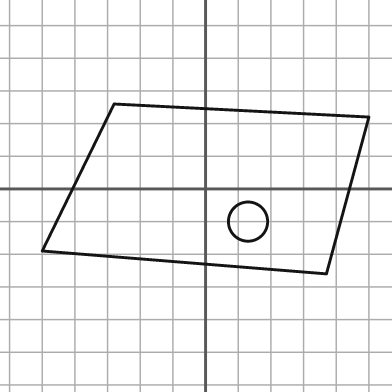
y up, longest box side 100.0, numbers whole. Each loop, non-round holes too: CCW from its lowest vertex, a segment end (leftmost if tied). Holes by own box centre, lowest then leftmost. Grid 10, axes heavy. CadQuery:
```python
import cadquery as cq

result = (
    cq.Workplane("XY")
    .moveTo(37.0, -26.0)
    .lineTo(50.0, 22.0)
    .lineTo(-28.0, 26.0)
    .lineTo(-50.0, -19.0)
    .close()
    .moveTo(13.0, -10.0)
    .circle(6.0)
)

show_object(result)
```